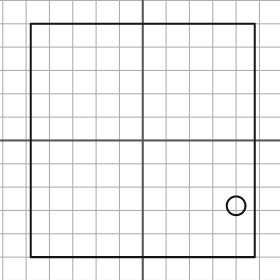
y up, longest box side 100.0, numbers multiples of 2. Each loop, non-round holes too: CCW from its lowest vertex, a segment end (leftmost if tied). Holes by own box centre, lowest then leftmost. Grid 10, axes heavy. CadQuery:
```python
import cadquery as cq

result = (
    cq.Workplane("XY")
    .moveTo(-48.0, -50.0)
    .lineTo(48.0, -50.0)
    .lineTo(48.0, 50.0)
    .lineTo(-48.0, 50.0)
    .close()
    .moveTo(40.0, -28.0)
    .circle(4.0)
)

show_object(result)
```